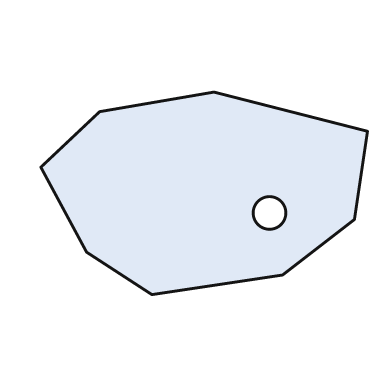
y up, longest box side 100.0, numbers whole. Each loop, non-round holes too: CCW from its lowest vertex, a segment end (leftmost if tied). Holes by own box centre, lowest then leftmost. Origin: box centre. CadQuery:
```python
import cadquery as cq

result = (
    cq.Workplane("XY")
    .moveTo(-16.0, -31.0)
    .lineTo(24.0, -25.0)
    .lineTo(46.0, -8.0)
    .lineTo(50.0, 19.0)
    .lineTo(3.0, 31.0)
    .lineTo(-32.0, 25.0)
    .lineTo(-50.0, 8.0)
    .lineTo(-36.0, -18.0)
    .close()
    .moveTo(20.0, -6.0)
    .circle(5.0)
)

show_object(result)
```